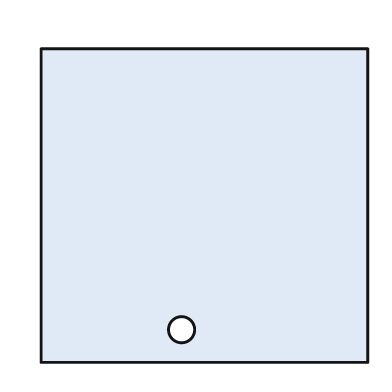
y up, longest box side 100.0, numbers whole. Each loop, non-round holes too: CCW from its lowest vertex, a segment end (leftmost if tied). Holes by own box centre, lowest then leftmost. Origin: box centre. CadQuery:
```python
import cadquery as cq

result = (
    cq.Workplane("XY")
    .moveTo(-50.0, -48.0)
    .lineTo(50.0, -48.0)
    .lineTo(50.0, 48.0)
    .lineTo(-50.0, 48.0)
    .close()
    .moveTo(-7.0, -38.0)
    .circle(4.0)
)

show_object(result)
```